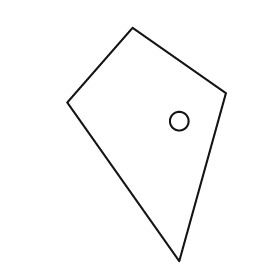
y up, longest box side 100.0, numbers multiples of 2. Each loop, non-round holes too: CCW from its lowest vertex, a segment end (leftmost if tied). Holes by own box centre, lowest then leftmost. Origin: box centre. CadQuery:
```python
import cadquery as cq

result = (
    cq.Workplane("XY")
    .moveTo(14.0, -50.0)
    .lineTo(34.0, 22.0)
    .lineTo(-6.0, 50.0)
    .lineTo(-34.0, 18.0)
    .close()
    .moveTo(14.0, 10.0)
    .circle(4.0)
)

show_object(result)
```